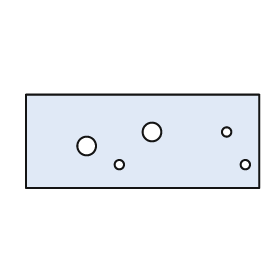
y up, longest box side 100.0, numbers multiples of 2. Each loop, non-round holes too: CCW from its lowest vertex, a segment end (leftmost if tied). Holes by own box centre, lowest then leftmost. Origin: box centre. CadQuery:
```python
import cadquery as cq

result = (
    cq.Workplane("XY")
    .moveTo(-50.0, -20.0)
    .lineTo(50.0, -20.0)
    .lineTo(50.0, 20.0)
    .lineTo(-50.0, 20.0)
    .close()
    .moveTo(-10.0, -10.0)
    .circle(2.0)
    .moveTo(44.0, -10.0)
    .circle(2.0)
    .moveTo(-24.0, -2.0)
    .circle(4.0)
    .moveTo(4.0, 4.0)
    .circle(4.0)
    .moveTo(36.0, 4.0)
    .circle(2.0)
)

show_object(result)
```